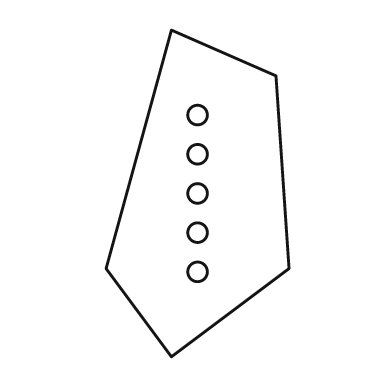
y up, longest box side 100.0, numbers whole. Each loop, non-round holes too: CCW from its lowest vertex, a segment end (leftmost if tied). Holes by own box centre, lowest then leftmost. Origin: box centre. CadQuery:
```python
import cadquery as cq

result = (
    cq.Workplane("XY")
    .moveTo(-8.0, -50.0)
    .lineTo(28.0, -23.0)
    .lineTo(24.0, 36.0)
    .lineTo(-8.0, 50.0)
    .lineTo(-28.0, -23.0)
    .close()
    .moveTo(0.0, -24.0)
    .circle(3.0)
    .moveTo(0.0, -12.0)
    .circle(3.0)
    .moveTo(0.0, 0.0)
    .circle(3.0)
    .moveTo(0.0, 12.0)
    .circle(3.0)
    .moveTo(0.0, 24.0)
    .circle(3.0)
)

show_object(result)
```